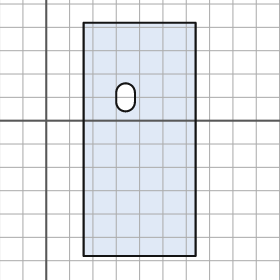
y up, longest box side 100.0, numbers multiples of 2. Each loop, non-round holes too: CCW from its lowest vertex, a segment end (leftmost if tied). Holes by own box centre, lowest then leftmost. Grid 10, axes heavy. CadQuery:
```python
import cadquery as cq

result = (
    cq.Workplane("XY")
    .moveTo(16.0, -58.0)
    .lineTo(64.0, -58.0)
    .lineTo(64.0, 42.0)
    .lineTo(16.0, 42.0)
    .close()
    .moveTo(30.0, 8.0)
    .threePointArc((34.0, 4.0), (38.0, 8.0))
    .lineTo(38.0, 12.0)
    .threePointArc((34.0, 16.0), (30.0, 12.0))
    .close()
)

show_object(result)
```